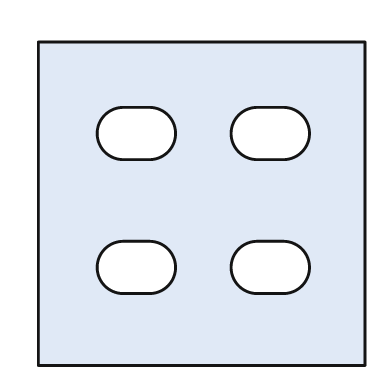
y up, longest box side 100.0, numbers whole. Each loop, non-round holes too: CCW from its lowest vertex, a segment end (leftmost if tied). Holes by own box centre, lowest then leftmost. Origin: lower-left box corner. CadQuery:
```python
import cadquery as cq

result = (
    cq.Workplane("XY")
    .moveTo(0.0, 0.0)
    .lineTo(100.0, 0.0)
    .lineTo(100.0, 99.0)
    .lineTo(0.0, 99.0)
    .close()
    .moveTo(26.0, 22.0)
    .lineTo(34.0, 22.0)
    .threePointArc((42.0, 30.0), (34.0, 38.0))
    .lineTo(26.0, 38.0)
    .threePointArc((18.0, 30.0), (26.0, 22.0))
    .close()
    .moveTo(67.0, 22.0)
    .lineTo(75.0, 22.0)
    .threePointArc((83.0, 30.0), (75.0, 38.0))
    .lineTo(67.0, 38.0)
    .threePointArc((59.0, 30.0), (67.0, 22.0))
    .close()
    .moveTo(26.0, 63.0)
    .lineTo(34.0, 63.0)
    .threePointArc((42.0, 71.0), (34.0, 79.0))
    .lineTo(26.0, 79.0)
    .threePointArc((18.0, 71.0), (26.0, 63.0))
    .close()
    .moveTo(67.0, 63.0)
    .lineTo(75.0, 63.0)
    .threePointArc((83.0, 71.0), (75.0, 79.0))
    .lineTo(67.0, 79.0)
    .threePointArc((59.0, 71.0), (67.0, 63.0))
    .close()
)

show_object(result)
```